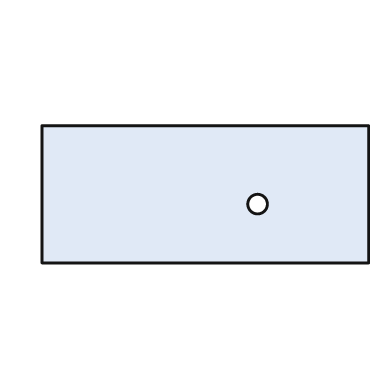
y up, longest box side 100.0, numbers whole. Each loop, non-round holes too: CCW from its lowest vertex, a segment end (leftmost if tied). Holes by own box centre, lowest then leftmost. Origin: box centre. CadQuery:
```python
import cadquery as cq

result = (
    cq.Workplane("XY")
    .moveTo(-50.0, -21.0)
    .lineTo(50.0, -21.0)
    .lineTo(50.0, 21.0)
    .lineTo(-50.0, 21.0)
    .close()
    .moveTo(16.0, -3.0)
    .circle(3.0)
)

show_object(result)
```